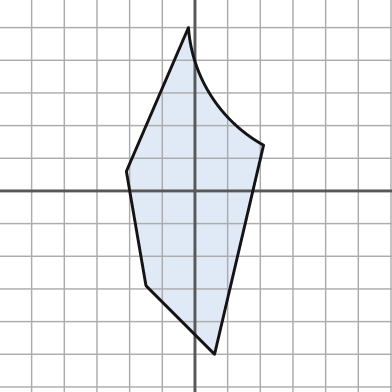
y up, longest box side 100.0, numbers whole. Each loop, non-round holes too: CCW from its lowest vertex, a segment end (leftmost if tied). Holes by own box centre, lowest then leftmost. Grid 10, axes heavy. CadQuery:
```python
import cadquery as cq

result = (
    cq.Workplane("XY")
    .moveTo(6.0, -50.0)
    .lineTo(21.0, 14.0)
    .threePointArc((5.0, 29.0), (-2.0, 50.0))
    .lineTo(-21.0, 6.0)
    .lineTo(-15.0, -29.0)
    .close()
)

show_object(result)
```